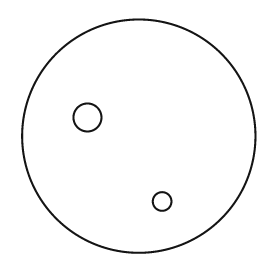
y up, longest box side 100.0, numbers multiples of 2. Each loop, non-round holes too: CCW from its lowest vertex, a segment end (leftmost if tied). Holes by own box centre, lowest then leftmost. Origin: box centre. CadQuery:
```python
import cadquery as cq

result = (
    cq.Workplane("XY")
    .moveTo(0.0, 0.0)
    .circle(50.0)
    .moveTo(10.0, -28.0)
    .circle(4.0)
    .moveTo(-22.0, 8.0)
    .circle(6.0)
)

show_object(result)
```